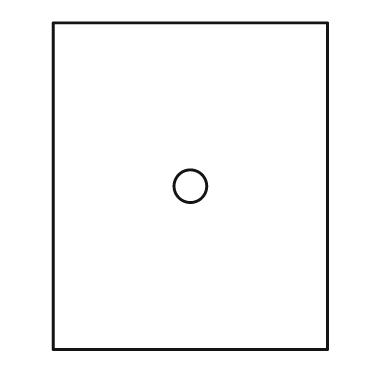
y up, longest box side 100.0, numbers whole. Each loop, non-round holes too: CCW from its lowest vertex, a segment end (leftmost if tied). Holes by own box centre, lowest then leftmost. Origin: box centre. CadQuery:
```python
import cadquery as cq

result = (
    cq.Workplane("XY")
    .moveTo(-42.0, -50.0)
    .lineTo(42.0, -50.0)
    .lineTo(42.0, 50.0)
    .lineTo(-42.0, 50.0)
    .close()
    .moveTo(0.0, 0.0)
    .circle(5.0)
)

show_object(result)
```